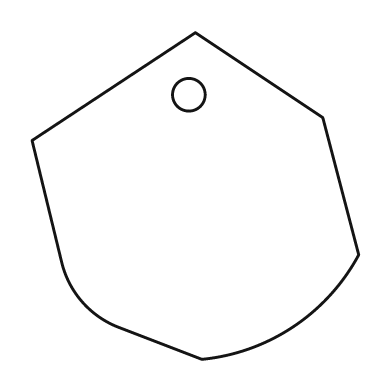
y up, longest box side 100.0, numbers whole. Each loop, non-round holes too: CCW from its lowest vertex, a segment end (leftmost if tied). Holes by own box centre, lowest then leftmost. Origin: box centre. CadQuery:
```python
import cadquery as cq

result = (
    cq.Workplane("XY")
    .moveTo(2.0, -50.0)
    .threePointArc((30.0, -40.0), (50.0, -18.0))
    .lineTo(39.0, 24.0)
    .lineTo(0.0, 50.0)
    .lineTo(-50.0, 17.0)
    .lineTo(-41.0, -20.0)
    .threePointArc((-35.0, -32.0), (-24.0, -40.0))
    .close()
    .moveTo(-2.0, 31.0)
    .circle(5.0)
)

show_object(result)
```